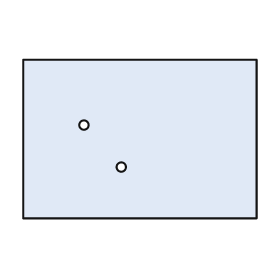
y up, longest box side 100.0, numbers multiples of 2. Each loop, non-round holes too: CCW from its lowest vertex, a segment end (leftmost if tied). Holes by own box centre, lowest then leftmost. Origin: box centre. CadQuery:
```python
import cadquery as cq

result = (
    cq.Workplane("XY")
    .moveTo(-50.0, -34.0)
    .lineTo(50.0, -34.0)
    .lineTo(50.0, 34.0)
    .lineTo(-50.0, 34.0)
    .close()
    .moveTo(-8.0, -12.0)
    .circle(2.0)
    .moveTo(-24.0, 6.0)
    .circle(2.0)
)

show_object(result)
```